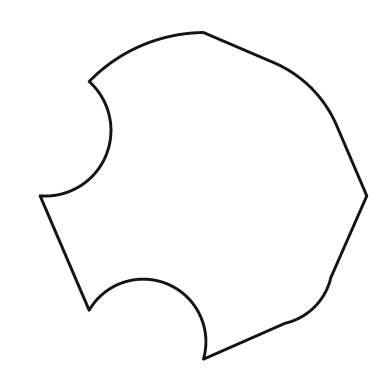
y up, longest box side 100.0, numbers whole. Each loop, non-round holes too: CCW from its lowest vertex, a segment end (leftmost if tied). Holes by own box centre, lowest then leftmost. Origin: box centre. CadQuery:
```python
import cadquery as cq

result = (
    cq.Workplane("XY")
    .moveTo(0.0, -50.0)
    .lineTo(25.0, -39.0)
    .threePointArc((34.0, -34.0), (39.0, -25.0))
    .lineTo(50.0, 0.0)
    .lineTo(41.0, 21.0)
    .threePointArc((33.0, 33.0), (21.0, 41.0))
    .lineTo(0.0, 50.0)
    .threePointArc((-19.0, 46.0), (-35.0, 35.0))
    .threePointArc((-30.0, 12.0), (-50.0, 0.0))
    .lineTo(-35.0, -35.0)
    .threePointArc((-11.0, -27.0), (0.0, -50.0))
    .close()
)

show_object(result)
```